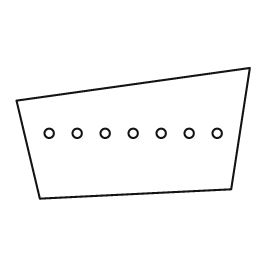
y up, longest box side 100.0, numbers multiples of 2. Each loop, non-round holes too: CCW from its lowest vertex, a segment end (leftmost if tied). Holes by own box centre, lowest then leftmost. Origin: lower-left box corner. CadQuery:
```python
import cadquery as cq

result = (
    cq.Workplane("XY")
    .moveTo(10.0, 0.0)
    .lineTo(92.0, 4.0)
    .lineTo(100.0, 56.0)
    .lineTo(0.0, 42.0)
    .close()
    .moveTo(14.0, 28.0)
    .circle(2.0)
    .moveTo(26.0, 28.0)
    .circle(2.0)
    .moveTo(38.0, 28.0)
    .circle(2.0)
    .moveTo(50.0, 28.0)
    .circle(2.0)
    .moveTo(62.0, 28.0)
    .circle(2.0)
    .moveTo(74.0, 28.0)
    .circle(2.0)
    .moveTo(86.0, 28.0)
    .circle(2.0)
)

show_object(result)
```